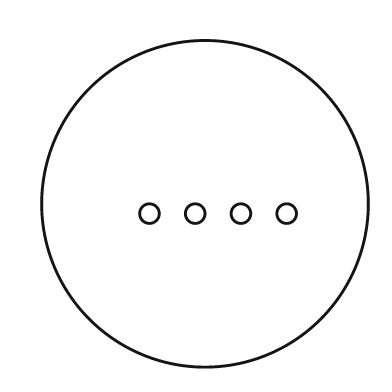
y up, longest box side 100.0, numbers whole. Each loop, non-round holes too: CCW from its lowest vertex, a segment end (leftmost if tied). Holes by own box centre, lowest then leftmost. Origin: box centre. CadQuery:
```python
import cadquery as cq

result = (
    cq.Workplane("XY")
    .moveTo(0.0, 0.0)
    .circle(50.0)
    .moveTo(-17.0, -3.0)
    .circle(3.0)
    .moveTo(-3.0, -3.0)
    .circle(3.0)
    .moveTo(11.0, -3.0)
    .circle(3.0)
    .moveTo(25.0, -3.0)
    .circle(3.0)
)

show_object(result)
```